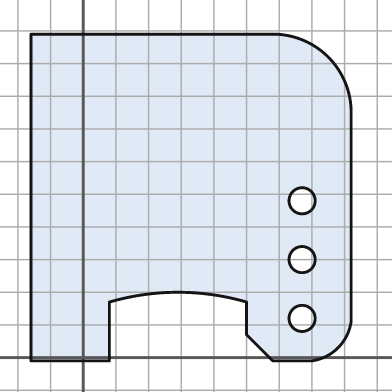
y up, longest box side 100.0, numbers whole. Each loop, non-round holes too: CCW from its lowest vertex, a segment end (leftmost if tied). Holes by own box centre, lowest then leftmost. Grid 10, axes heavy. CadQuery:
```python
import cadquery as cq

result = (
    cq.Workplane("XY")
    .moveTo(-16.0, -1.0)
    .lineTo(8.0, -1.0)
    .lineTo(8.0, 17.0)
    .threePointArc((29.0, 20.0), (50.0, 17.0))
    .lineTo(50.0, 7.0)
    .lineTo(58.0, -1.0)
    .lineTo(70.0, -1.0)
    .threePointArc((78.0, 3.0), (82.0, 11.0))
    .lineTo(82.0, 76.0)
    .threePointArc((75.0, 92.0), (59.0, 99.0))
    .lineTo(-16.0, 99.0)
    .close()
    .moveTo(67.0, 12.0)
    .circle(4.0)
    .moveTo(67.0, 30.0)
    .circle(4.0)
    .moveTo(67.0, 48.0)
    .circle(4.0)
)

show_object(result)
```